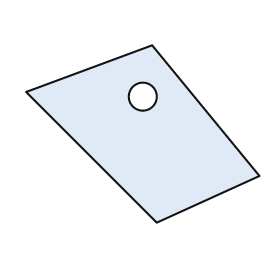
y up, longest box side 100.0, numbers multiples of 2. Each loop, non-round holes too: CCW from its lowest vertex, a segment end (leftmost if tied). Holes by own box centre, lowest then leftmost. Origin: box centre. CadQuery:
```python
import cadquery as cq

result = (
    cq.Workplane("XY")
    .moveTo(6.0, -38.0)
    .lineTo(50.0, -18.0)
    .lineTo(4.0, 38.0)
    .lineTo(-50.0, 18.0)
    .close()
    .moveTo(0.0, 16.0)
    .circle(6.0)
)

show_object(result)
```